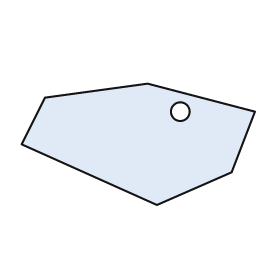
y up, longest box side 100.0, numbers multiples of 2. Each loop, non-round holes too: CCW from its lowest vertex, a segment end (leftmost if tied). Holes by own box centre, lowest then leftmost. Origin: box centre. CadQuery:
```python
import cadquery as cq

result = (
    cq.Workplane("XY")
    .moveTo(8.0, -26.0)
    .lineTo(40.0, -12.0)
    .lineTo(50.0, 14.0)
    .lineTo(4.0, 26.0)
    .lineTo(-40.0, 20.0)
    .lineTo(-50.0, 0.0)
    .close()
    .moveTo(18.0, 14.0)
    .circle(4.0)
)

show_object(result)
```